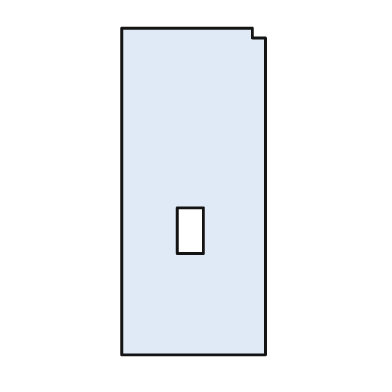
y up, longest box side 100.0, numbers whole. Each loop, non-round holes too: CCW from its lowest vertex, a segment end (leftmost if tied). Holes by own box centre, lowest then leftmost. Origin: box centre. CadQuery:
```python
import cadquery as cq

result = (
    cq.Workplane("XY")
    .moveTo(-22.0, -50.0)
    .lineTo(22.0, -50.0)
    .lineTo(22.0, 47.0)
    .lineTo(18.0, 47.0)
    .lineTo(18.0, 50.0)
    .lineTo(-22.0, 50.0)
    .close()
    .moveTo(-5.0, -19.0)
    .lineTo(3.0, -19.0)
    .lineTo(3.0, -5.0)
    .lineTo(-5.0, -5.0)
    .close()
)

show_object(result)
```